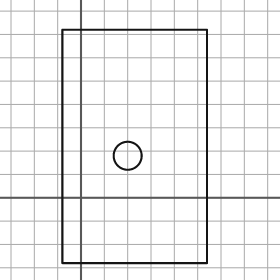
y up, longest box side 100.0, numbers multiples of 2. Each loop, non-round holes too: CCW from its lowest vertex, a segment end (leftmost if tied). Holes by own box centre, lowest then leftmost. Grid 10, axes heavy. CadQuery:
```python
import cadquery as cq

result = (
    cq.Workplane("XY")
    .moveTo(-8.0, -28.0)
    .lineTo(54.0, -28.0)
    .lineTo(54.0, 72.0)
    .lineTo(-8.0, 72.0)
    .close()
    .moveTo(20.0, 18.0)
    .circle(6.0)
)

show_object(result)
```